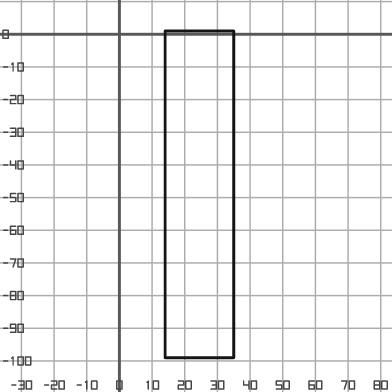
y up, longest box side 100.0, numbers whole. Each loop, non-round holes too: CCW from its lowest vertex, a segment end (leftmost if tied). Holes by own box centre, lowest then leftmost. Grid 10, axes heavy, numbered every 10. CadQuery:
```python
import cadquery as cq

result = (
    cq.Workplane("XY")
    .moveTo(14.0, -99.0)
    .lineTo(35.0, -99.0)
    .lineTo(35.0, 1.0)
    .lineTo(14.0, 1.0)
    .close()
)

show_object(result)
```